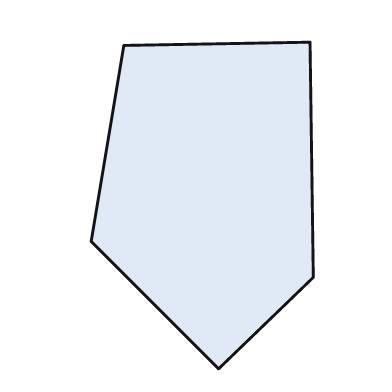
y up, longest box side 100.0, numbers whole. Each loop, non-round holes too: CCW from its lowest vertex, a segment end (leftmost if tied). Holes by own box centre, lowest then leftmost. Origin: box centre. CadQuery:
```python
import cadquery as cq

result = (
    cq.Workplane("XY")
    .moveTo(5.0, -50.0)
    .lineTo(34.0, -22.0)
    .lineTo(33.0, 50.0)
    .lineTo(-24.0, 49.0)
    .lineTo(-34.0, -11.0)
    .close()
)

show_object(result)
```